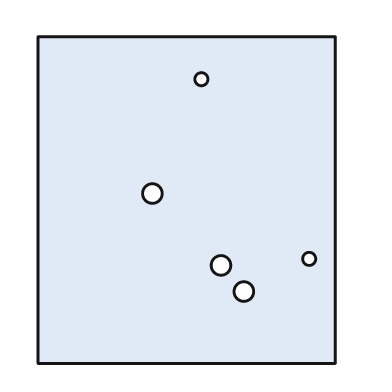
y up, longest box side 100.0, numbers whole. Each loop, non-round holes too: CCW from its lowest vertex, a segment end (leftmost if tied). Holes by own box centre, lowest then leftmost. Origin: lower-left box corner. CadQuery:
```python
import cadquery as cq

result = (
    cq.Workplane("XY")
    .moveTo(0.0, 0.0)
    .lineTo(91.0, 0.0)
    .lineTo(91.0, 100.0)
    .lineTo(0.0, 100.0)
    .close()
    .moveTo(63.0, 22.0)
    .circle(3.0)
    .moveTo(56.0, 30.0)
    .circle(3.0)
    .moveTo(83.0, 32.0)
    .circle(2.0)
    .moveTo(35.0, 52.0)
    .circle(3.0)
    .moveTo(50.0, 87.0)
    .circle(2.0)
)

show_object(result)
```